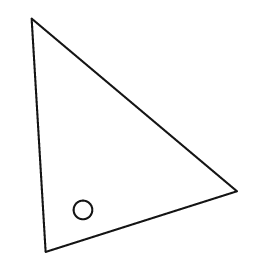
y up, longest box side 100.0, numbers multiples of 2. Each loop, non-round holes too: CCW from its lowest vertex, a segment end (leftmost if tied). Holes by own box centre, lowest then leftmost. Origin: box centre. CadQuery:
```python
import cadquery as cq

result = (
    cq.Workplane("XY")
    .moveTo(-38.0, -50.0)
    .lineTo(44.0, -24.0)
    .lineTo(-44.0, 50.0)
    .close()
    .moveTo(-22.0, -32.0)
    .circle(4.0)
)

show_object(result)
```